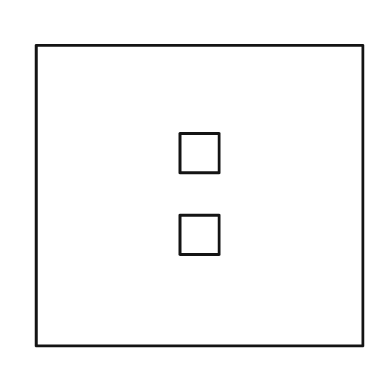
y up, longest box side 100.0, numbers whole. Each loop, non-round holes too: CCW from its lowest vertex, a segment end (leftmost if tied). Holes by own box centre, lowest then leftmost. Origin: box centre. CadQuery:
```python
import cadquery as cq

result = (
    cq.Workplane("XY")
    .moveTo(-50.0, -46.0)
    .lineTo(50.0, -46.0)
    .lineTo(50.0, 46.0)
    .lineTo(-50.0, 46.0)
    .close()
    .moveTo(-6.0, -18.0)
    .lineTo(6.0, -18.0)
    .lineTo(6.0, -6.0)
    .lineTo(-6.0, -6.0)
    .close()
    .moveTo(-6.0, 7.0)
    .lineTo(6.0, 7.0)
    .lineTo(6.0, 19.0)
    .lineTo(-6.0, 19.0)
    .close()
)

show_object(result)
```